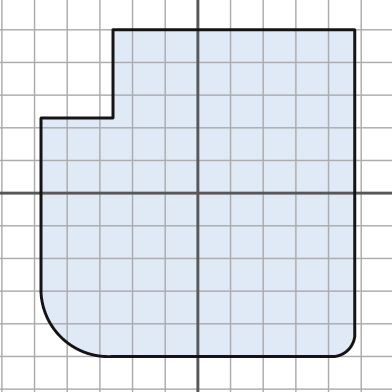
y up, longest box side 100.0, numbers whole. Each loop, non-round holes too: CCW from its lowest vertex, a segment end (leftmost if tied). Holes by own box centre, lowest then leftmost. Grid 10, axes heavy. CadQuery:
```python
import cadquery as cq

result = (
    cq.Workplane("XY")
    .moveTo(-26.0, -50.0)
    .lineTo(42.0, -50.0)
    .threePointArc((46.0, -48.0), (48.0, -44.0))
    .lineTo(48.0, 50.0)
    .lineTo(-26.0, 50.0)
    .lineTo(-26.0, 23.0)
    .lineTo(-48.0, 23.0)
    .lineTo(-48.0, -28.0)
    .threePointArc((-42.0, -44.0), (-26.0, -50.0))
    .close()
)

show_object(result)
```